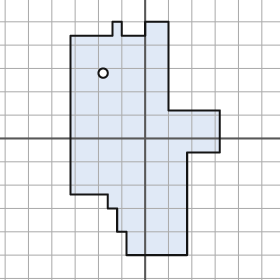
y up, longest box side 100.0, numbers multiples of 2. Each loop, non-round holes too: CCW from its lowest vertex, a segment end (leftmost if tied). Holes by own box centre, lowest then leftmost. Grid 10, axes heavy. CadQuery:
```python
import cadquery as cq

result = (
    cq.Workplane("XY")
    .moveTo(-8.0, -50.0)
    .lineTo(18.0, -50.0)
    .lineTo(18.0, -6.0)
    .lineTo(32.0, -6.0)
    .lineTo(32.0, 12.0)
    .lineTo(10.0, 12.0)
    .lineTo(10.0, 50.0)
    .lineTo(0.0, 50.0)
    .lineTo(0.0, 44.0)
    .lineTo(-10.0, 44.0)
    .lineTo(-10.0, 50.0)
    .lineTo(-14.0, 50.0)
    .lineTo(-14.0, 44.0)
    .lineTo(-32.0, 44.0)
    .lineTo(-32.0, -24.0)
    .lineTo(-16.0, -24.0)
    .lineTo(-16.0, -30.0)
    .lineTo(-12.0, -30.0)
    .lineTo(-12.0, -40.0)
    .lineTo(-8.0, -40.0)
    .close()
    .moveTo(-18.0, 28.0)
    .circle(2.0)
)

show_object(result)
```